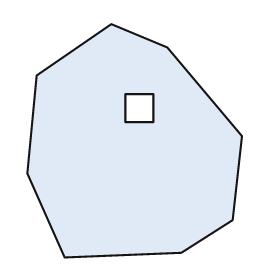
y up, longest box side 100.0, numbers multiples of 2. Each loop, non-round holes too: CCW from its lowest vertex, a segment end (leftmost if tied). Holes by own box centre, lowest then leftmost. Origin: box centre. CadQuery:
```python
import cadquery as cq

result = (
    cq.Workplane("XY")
    .moveTo(-30.0, -50.0)
    .lineTo(20.0, -48.0)
    .lineTo(42.0, -34.0)
    .lineTo(46.0, 2.0)
    .lineTo(14.0, 40.0)
    .lineTo(-10.0, 50.0)
    .lineTo(-42.0, 28.0)
    .lineTo(-46.0, -14.0)
    .close()
    .moveTo(-4.0, 8.0)
    .lineTo(8.0, 8.0)
    .lineTo(8.0, 20.0)
    .lineTo(-4.0, 20.0)
    .close()
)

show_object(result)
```